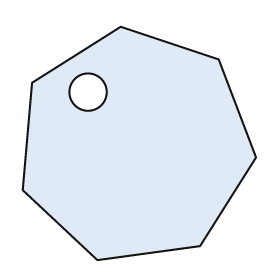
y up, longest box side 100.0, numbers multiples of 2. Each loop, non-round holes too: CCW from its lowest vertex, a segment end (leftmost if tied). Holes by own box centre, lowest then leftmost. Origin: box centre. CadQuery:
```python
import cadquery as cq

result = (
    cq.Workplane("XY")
    .moveTo(-18.0, -50.0)
    .lineTo(26.0, -44.0)
    .lineTo(50.0, -6.0)
    .lineTo(34.0, 36.0)
    .lineTo(-8.0, 50.0)
    .lineTo(-46.0, 26.0)
    .lineTo(-50.0, -20.0)
    .close()
    .moveTo(-22.0, 22.0)
    .circle(8.0)
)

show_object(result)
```